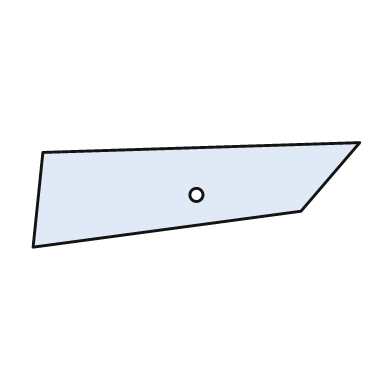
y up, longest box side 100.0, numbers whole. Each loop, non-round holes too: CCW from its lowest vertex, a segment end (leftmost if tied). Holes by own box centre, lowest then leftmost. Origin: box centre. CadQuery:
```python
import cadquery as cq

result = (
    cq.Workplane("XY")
    .moveTo(-50.0, -16.0)
    .lineTo(32.0, -5.0)
    .lineTo(50.0, 16.0)
    .lineTo(-47.0, 13.0)
    .close()
    .moveTo(0.0, 0.0)
    .circle(2.0)
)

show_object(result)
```